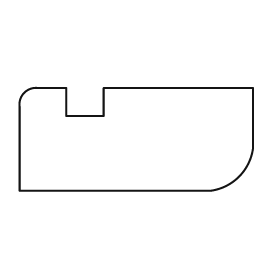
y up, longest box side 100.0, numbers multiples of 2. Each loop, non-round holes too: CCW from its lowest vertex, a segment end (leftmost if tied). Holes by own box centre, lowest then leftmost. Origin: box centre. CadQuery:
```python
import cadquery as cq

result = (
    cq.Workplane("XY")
    .moveTo(-50.0, -22.0)
    .lineTo(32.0, -22.0)
    .threePointArc((44.0, -16.0), (50.0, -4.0))
    .lineTo(50.0, 22.0)
    .lineTo(-14.0, 22.0)
    .lineTo(-14.0, 10.0)
    .lineTo(-30.0, 10.0)
    .lineTo(-30.0, 22.0)
    .lineTo(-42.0, 22.0)
    .threePointArc((-48.0, 20.0), (-50.0, 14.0))
    .close()
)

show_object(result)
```